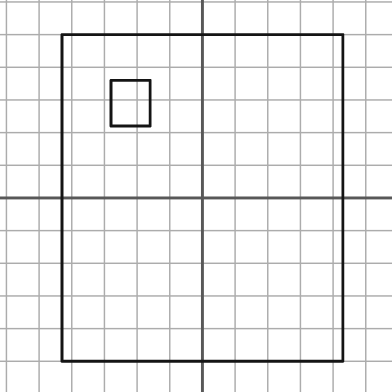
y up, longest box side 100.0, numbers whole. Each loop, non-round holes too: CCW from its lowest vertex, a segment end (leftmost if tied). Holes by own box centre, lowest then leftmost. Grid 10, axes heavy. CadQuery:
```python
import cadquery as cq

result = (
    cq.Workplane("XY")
    .moveTo(-43.0, -50.0)
    .lineTo(43.0, -50.0)
    .lineTo(43.0, 50.0)
    .lineTo(-43.0, 50.0)
    .close()
    .moveTo(-28.0, 22.0)
    .lineTo(-16.0, 22.0)
    .lineTo(-16.0, 36.0)
    .lineTo(-28.0, 36.0)
    .close()
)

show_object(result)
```